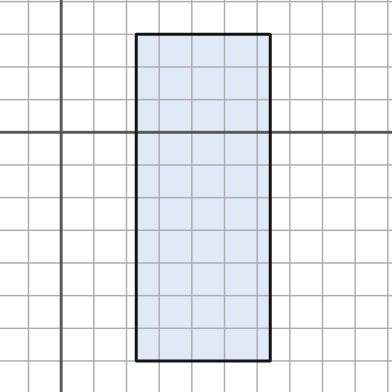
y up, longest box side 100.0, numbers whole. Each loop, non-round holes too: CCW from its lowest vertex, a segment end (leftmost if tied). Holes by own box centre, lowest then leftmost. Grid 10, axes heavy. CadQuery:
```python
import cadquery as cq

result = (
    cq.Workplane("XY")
    .moveTo(23.0, -70.0)
    .lineTo(64.0, -70.0)
    .lineTo(64.0, 30.0)
    .lineTo(23.0, 30.0)
    .close()
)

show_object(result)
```